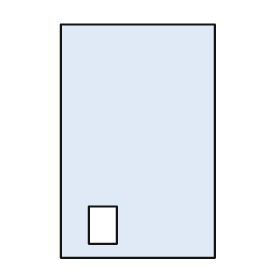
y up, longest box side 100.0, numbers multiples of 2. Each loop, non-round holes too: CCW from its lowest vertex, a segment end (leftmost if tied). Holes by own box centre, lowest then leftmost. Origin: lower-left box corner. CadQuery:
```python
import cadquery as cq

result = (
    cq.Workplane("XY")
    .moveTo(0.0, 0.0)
    .lineTo(66.0, 0.0)
    .lineTo(66.0, 100.0)
    .lineTo(0.0, 100.0)
    .close()
    .moveTo(12.0, 6.0)
    .lineTo(24.0, 6.0)
    .lineTo(24.0, 22.0)
    .lineTo(12.0, 22.0)
    .close()
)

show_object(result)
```